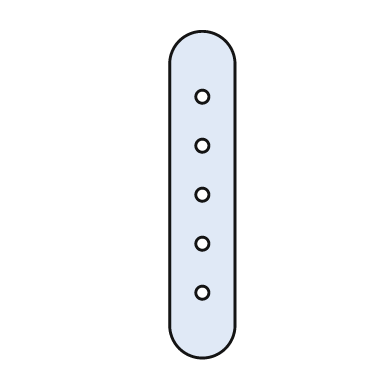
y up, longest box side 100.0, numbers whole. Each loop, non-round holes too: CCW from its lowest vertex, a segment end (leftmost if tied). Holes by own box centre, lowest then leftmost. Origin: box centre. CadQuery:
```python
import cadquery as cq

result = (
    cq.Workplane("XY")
    .moveTo(-10.0, -40.0)
    .threePointArc((0.0, -50.0), (10.0, -40.0))
    .lineTo(10.0, 40.0)
    .threePointArc((0.0, 50.0), (-10.0, 40.0))
    .close()
    .moveTo(0.0, -30.0)
    .circle(2.0)
    .moveTo(0.0, -15.0)
    .circle(2.0)
    .moveTo(0.0, 0.0)
    .circle(2.0)
    .moveTo(0.0, 15.0)
    .circle(2.0)
    .moveTo(0.0, 30.0)
    .circle(2.0)
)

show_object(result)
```